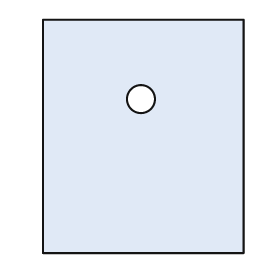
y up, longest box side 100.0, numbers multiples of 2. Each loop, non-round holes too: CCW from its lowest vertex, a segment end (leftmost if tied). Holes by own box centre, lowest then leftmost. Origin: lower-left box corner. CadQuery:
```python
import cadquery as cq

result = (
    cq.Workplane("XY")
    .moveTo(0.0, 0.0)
    .lineTo(86.0, 0.0)
    .lineTo(86.0, 100.0)
    .lineTo(0.0, 100.0)
    .close()
    .moveTo(42.0, 66.0)
    .circle(6.0)
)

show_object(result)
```